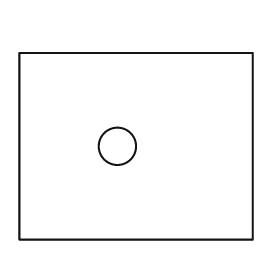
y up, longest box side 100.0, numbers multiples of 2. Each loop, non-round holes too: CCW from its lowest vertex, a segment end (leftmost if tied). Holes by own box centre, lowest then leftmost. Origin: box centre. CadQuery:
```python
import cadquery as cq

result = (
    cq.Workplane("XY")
    .moveTo(-50.0, -40.0)
    .lineTo(50.0, -40.0)
    .lineTo(50.0, 40.0)
    .lineTo(-50.0, 40.0)
    .close()
    .moveTo(-8.0, 0.0)
    .circle(8.0)
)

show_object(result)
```